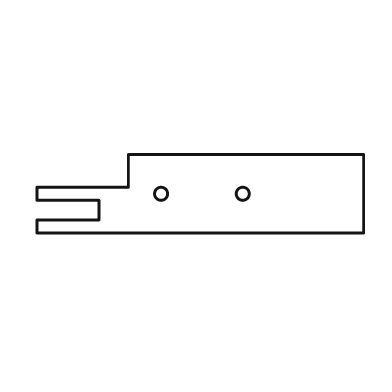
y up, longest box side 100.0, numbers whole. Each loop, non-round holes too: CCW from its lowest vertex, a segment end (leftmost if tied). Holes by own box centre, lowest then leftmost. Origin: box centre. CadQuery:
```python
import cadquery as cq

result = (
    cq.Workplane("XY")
    .moveTo(-50.0, -12.0)
    .lineTo(50.0, -12.0)
    .lineTo(50.0, 12.0)
    .lineTo(-22.0, 12.0)
    .lineTo(-22.0, 2.0)
    .lineTo(-50.0, 2.0)
    .lineTo(-50.0, -2.0)
    .lineTo(-31.0, -2.0)
    .lineTo(-31.0, -8.0)
    .lineTo(-50.0, -8.0)
    .close()
    .moveTo(-12.0, 0.0)
    .circle(2.0)
    .moveTo(13.0, 0.0)
    .circle(2.0)
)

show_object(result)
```